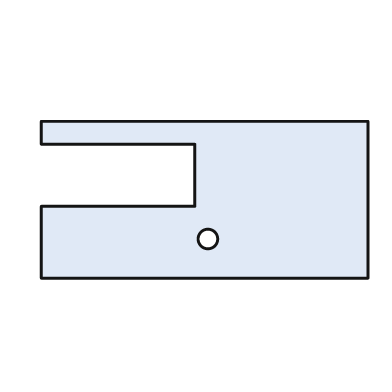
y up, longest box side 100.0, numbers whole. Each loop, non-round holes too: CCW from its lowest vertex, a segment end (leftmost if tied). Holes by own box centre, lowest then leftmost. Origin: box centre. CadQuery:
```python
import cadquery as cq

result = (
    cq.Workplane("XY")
    .moveTo(-50.0, -24.0)
    .lineTo(50.0, -24.0)
    .lineTo(50.0, 24.0)
    .lineTo(-50.0, 24.0)
    .lineTo(-50.0, 17.0)
    .lineTo(-3.0, 17.0)
    .lineTo(-3.0, -2.0)
    .lineTo(-50.0, -2.0)
    .close()
    .moveTo(1.0, -12.0)
    .circle(3.0)
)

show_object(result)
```